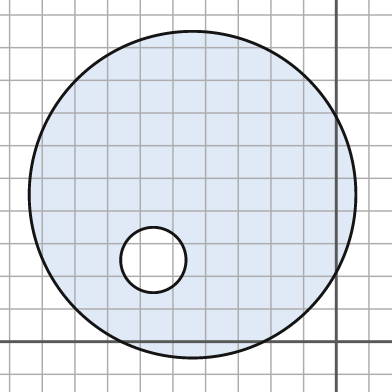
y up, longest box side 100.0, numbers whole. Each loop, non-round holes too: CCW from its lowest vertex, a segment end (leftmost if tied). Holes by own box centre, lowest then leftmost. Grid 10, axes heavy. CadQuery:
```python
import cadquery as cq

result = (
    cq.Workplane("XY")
    .moveTo(-44.0, 45.0)
    .circle(50.0)
    .moveTo(-56.0, 25.0)
    .circle(10.0)
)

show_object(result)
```